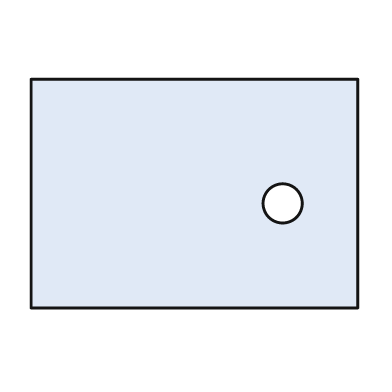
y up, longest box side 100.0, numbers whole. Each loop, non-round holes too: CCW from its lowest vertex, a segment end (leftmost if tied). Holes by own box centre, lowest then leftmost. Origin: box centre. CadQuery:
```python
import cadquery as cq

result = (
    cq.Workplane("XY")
    .moveTo(-50.0, -35.0)
    .lineTo(50.0, -35.0)
    .lineTo(50.0, 35.0)
    .lineTo(-50.0, 35.0)
    .close()
    .moveTo(27.0, -3.0)
    .circle(6.0)
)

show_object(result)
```